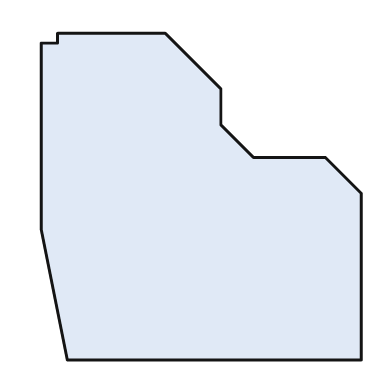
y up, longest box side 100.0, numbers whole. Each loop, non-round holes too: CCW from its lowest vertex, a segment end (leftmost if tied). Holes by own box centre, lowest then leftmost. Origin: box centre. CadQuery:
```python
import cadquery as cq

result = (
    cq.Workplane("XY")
    .moveTo(-41.0, -50.0)
    .lineTo(49.0, -50.0)
    .lineTo(49.0, 1.0)
    .lineTo(38.0, 12.0)
    .lineTo(16.0, 12.0)
    .lineTo(6.0, 22.0)
    .lineTo(6.0, 33.0)
    .lineTo(-11.0, 50.0)
    .lineTo(-44.0, 50.0)
    .lineTo(-44.0, 47.0)
    .lineTo(-49.0, 47.0)
    .lineTo(-49.0, -10.0)
    .close()
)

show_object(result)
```